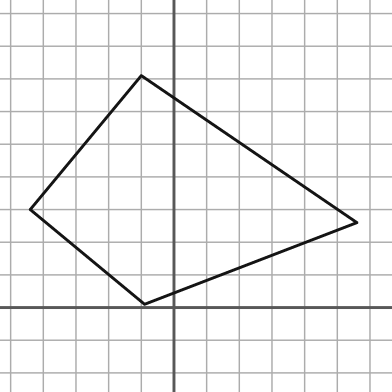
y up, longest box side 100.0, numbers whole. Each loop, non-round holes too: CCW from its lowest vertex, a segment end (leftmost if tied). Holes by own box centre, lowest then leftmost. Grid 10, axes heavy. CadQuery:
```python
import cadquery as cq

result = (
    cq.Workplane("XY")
    .moveTo(-9.0, 1.0)
    .lineTo(56.0, 26.0)
    .lineTo(-10.0, 71.0)
    .lineTo(-44.0, 30.0)
    .close()
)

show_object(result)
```